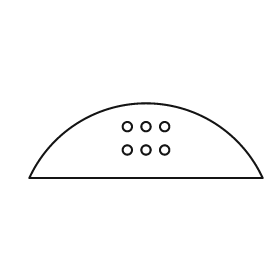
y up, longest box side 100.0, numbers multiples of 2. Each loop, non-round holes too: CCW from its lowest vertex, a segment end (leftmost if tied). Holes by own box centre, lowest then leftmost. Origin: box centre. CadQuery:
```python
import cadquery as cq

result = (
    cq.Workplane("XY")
    .moveTo(-50.0, -16.0)
    .lineTo(50.0, -16.0)
    .threePointArc((0.0, 16.0), (-50.0, -16.0))
    .close()
    .moveTo(-8.0, -4.0)
    .circle(2.0)
    .moveTo(0.0, -4.0)
    .circle(2.0)
    .moveTo(8.0, -4.0)
    .circle(2.0)
    .moveTo(-8.0, 6.0)
    .circle(2.0)
    .moveTo(0.0, 6.0)
    .circle(2.0)
    .moveTo(8.0, 6.0)
    .circle(2.0)
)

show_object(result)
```